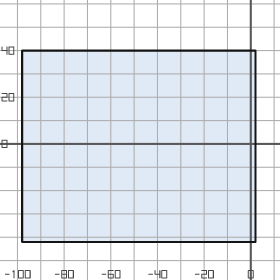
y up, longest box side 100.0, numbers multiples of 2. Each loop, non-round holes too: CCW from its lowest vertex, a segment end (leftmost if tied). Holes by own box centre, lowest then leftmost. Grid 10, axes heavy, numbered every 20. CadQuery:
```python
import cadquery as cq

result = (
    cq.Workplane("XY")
    .moveTo(-98.0, -42.0)
    .lineTo(2.0, -42.0)
    .lineTo(2.0, 40.0)
    .lineTo(-98.0, 40.0)
    .close()
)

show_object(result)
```